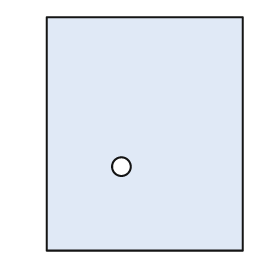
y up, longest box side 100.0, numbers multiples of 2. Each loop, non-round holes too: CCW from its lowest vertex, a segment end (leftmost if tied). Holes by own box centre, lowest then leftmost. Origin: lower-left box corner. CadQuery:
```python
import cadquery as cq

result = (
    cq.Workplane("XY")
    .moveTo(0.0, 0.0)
    .lineTo(84.0, 0.0)
    .lineTo(84.0, 100.0)
    .lineTo(0.0, 100.0)
    .close()
    .moveTo(32.0, 36.0)
    .circle(4.0)
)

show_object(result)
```